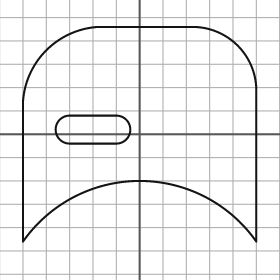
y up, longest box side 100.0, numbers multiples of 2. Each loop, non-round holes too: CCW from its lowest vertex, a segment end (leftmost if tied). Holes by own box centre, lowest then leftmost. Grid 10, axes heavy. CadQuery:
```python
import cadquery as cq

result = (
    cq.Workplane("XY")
    .moveTo(-50.0, -46.0)
    .threePointArc((0.0, -20.0), (50.0, -46.0))
    .lineTo(50.0, 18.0)
    .threePointArc((42.0, 38.0), (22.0, 46.0))
    .lineTo(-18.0, 46.0)
    .threePointArc((-40.0, 36.0), (-50.0, 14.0))
    .close()
    .moveTo(-30.0, -4.0)
    .lineTo(-10.0, -4.0)
    .threePointArc((-4.0, 2.0), (-10.0, 8.0))
    .lineTo(-30.0, 8.0)
    .threePointArc((-36.0, 2.0), (-30.0, -4.0))
    .close()
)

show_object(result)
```